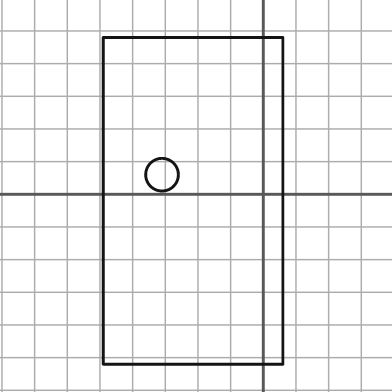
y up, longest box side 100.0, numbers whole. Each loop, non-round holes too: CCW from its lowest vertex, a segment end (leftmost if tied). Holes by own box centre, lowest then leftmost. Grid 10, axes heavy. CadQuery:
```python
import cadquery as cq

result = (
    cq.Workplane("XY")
    .moveTo(-49.0, -52.0)
    .lineTo(6.0, -52.0)
    .lineTo(6.0, 48.0)
    .lineTo(-49.0, 48.0)
    .close()
    .moveTo(-31.0, 6.0)
    .circle(5.0)
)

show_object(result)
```